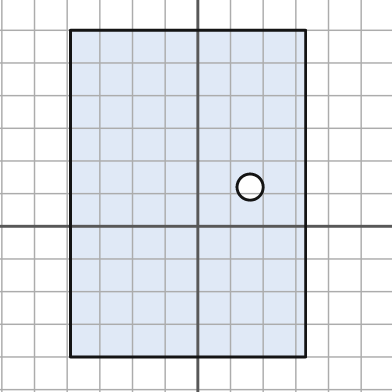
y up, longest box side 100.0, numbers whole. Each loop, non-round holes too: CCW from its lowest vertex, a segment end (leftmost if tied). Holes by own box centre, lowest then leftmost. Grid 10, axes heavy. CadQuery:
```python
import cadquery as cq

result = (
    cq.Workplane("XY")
    .moveTo(-39.0, -40.0)
    .lineTo(33.0, -40.0)
    .lineTo(33.0, 60.0)
    .lineTo(-39.0, 60.0)
    .close()
    .moveTo(16.0, 12.0)
    .circle(4.0)
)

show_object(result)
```